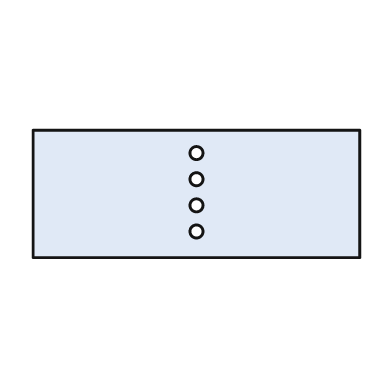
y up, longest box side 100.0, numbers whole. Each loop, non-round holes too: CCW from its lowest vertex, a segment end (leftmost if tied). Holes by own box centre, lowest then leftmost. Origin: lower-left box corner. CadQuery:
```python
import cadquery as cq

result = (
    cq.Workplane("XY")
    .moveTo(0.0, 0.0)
    .lineTo(100.0, 0.0)
    .lineTo(100.0, 39.0)
    .lineTo(0.0, 39.0)
    .close()
    .moveTo(50.0, 8.0)
    .circle(2.0)
    .moveTo(50.0, 16.0)
    .circle(2.0)
    .moveTo(50.0, 24.0)
    .circle(2.0)
    .moveTo(50.0, 32.0)
    .circle(2.0)
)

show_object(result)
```